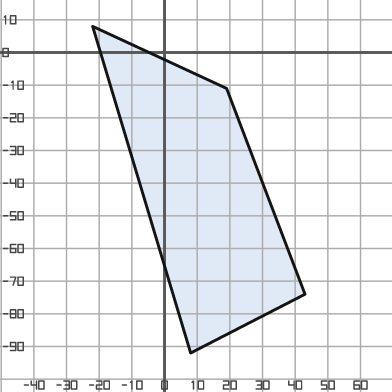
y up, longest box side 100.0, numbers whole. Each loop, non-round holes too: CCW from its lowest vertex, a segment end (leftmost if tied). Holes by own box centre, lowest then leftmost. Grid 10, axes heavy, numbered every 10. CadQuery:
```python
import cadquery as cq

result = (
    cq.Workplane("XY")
    .moveTo(8.0, -92.0)
    .lineTo(43.0, -74.0)
    .lineTo(19.0, -11.0)
    .lineTo(-22.0, 8.0)
    .close()
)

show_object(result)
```